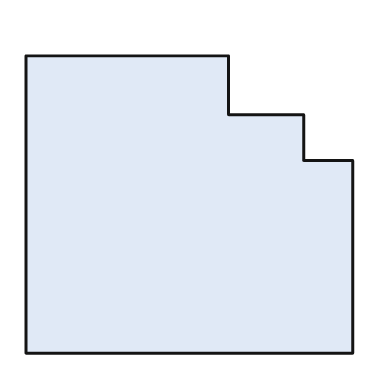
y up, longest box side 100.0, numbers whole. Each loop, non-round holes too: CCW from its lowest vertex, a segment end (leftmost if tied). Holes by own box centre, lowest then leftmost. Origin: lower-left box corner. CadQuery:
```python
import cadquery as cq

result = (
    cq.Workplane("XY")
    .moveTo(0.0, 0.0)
    .lineTo(100.0, 0.0)
    .lineTo(100.0, 59.0)
    .lineTo(85.0, 59.0)
    .lineTo(85.0, 73.0)
    .lineTo(62.0, 73.0)
    .lineTo(62.0, 91.0)
    .lineTo(0.0, 91.0)
    .close()
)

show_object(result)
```